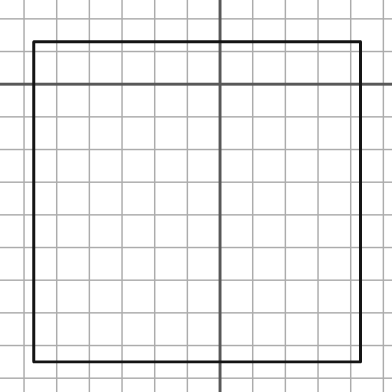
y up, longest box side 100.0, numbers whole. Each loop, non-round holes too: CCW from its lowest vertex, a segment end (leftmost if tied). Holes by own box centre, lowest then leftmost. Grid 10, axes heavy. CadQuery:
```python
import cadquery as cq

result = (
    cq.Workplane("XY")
    .moveTo(-57.0, -85.0)
    .lineTo(43.0, -85.0)
    .lineTo(43.0, 13.0)
    .lineTo(-57.0, 13.0)
    .close()
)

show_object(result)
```